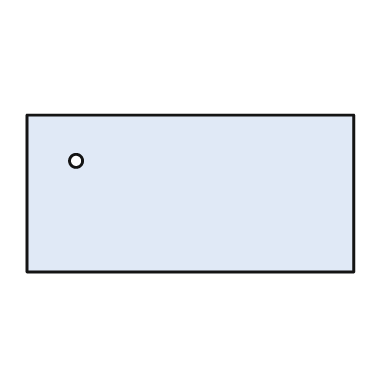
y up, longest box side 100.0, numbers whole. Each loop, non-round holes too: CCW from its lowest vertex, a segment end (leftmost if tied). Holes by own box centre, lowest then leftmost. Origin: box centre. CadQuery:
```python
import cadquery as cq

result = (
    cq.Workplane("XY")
    .moveTo(-50.0, -24.0)
    .lineTo(50.0, -24.0)
    .lineTo(50.0, 24.0)
    .lineTo(-50.0, 24.0)
    .close()
    .moveTo(-35.0, 10.0)
    .circle(2.0)
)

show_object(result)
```